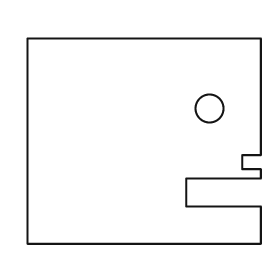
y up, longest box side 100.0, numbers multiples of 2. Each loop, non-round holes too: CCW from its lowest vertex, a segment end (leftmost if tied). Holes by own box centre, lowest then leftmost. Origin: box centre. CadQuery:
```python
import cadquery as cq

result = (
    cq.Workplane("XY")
    .moveTo(-50.0, -44.0)
    .lineTo(50.0, -44.0)
    .lineTo(50.0, -28.0)
    .lineTo(18.0, -28.0)
    .lineTo(18.0, -16.0)
    .lineTo(50.0, -16.0)
    .lineTo(50.0, -12.0)
    .lineTo(42.0, -12.0)
    .lineTo(42.0, -6.0)
    .lineTo(50.0, -6.0)
    .lineTo(50.0, 44.0)
    .lineTo(-50.0, 44.0)
    .close()
    .moveTo(28.0, 14.0)
    .circle(6.0)
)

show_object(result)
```